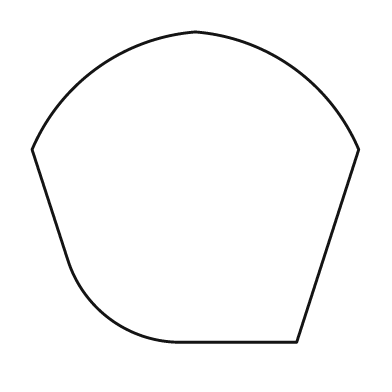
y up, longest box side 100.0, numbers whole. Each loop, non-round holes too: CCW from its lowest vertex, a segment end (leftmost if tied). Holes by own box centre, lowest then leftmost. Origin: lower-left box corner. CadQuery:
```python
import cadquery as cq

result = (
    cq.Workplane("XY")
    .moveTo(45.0, 0.0)
    .lineTo(81.0, 0.0)
    .lineTo(100.0, 59.0)
    .threePointArc((80.0, 84.0), (50.0, 95.0))
    .threePointArc((20.0, 84.0), (0.0, 59.0))
    .lineTo(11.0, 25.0)
    .threePointArc((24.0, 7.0), (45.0, 0.0))
    .close()
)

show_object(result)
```